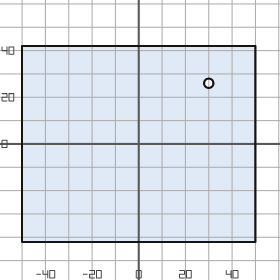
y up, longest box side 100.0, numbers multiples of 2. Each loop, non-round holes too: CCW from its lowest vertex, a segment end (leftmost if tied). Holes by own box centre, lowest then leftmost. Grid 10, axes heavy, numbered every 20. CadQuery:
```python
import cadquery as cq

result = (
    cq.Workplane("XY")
    .moveTo(-50.0, -42.0)
    .lineTo(50.0, -42.0)
    .lineTo(50.0, 42.0)
    .lineTo(-50.0, 42.0)
    .close()
    .moveTo(30.0, 26.0)
    .circle(2.0)
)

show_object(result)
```